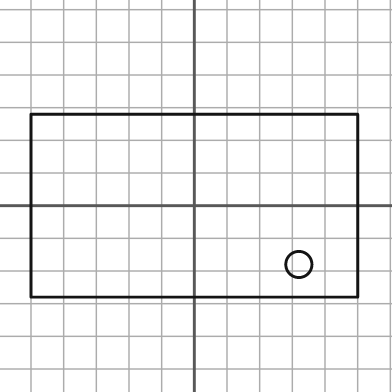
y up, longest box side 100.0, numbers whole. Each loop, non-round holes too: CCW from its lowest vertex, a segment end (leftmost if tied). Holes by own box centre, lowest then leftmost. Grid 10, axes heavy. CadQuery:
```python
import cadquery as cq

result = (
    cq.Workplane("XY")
    .moveTo(-50.0, -28.0)
    .lineTo(50.0, -28.0)
    .lineTo(50.0, 28.0)
    .lineTo(-50.0, 28.0)
    .close()
    .moveTo(32.0, -18.0)
    .circle(4.0)
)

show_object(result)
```